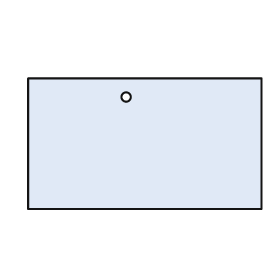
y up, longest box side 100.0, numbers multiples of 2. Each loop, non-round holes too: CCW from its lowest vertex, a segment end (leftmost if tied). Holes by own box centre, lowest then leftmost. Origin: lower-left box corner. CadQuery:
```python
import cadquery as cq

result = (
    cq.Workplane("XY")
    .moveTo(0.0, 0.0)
    .lineTo(100.0, 0.0)
    .lineTo(100.0, 56.0)
    .lineTo(0.0, 56.0)
    .close()
    .moveTo(42.0, 48.0)
    .circle(2.0)
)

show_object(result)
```